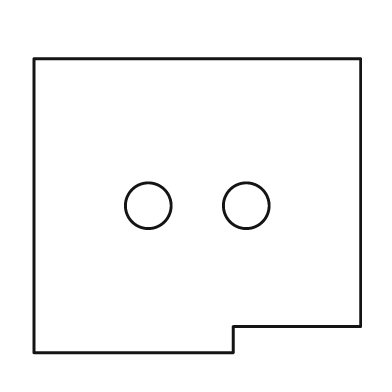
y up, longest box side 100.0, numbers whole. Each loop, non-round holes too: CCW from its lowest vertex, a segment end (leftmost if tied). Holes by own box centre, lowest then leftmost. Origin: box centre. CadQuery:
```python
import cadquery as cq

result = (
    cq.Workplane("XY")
    .moveTo(-50.0, -45.0)
    .lineTo(11.0, -45.0)
    .lineTo(11.0, -37.0)
    .lineTo(50.0, -37.0)
    .lineTo(50.0, 45.0)
    .lineTo(-50.0, 45.0)
    .close()
    .moveTo(-15.0, 0.0)
    .circle(7.0)
    .moveTo(15.0, 0.0)
    .circle(7.0)
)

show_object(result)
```